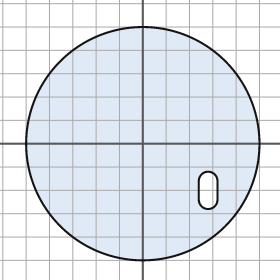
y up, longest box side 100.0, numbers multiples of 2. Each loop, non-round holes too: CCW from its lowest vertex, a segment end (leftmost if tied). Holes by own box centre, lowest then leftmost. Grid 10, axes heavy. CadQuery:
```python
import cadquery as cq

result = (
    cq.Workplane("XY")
    .moveTo(0.0, 0.0)
    .circle(50.0)
    .moveTo(24.0, -24.0)
    .threePointArc((28.0, -28.0), (32.0, -24.0))
    .lineTo(32.0, -16.0)
    .threePointArc((28.0, -12.0), (24.0, -16.0))
    .close()
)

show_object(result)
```